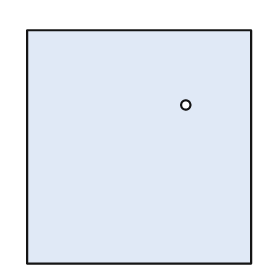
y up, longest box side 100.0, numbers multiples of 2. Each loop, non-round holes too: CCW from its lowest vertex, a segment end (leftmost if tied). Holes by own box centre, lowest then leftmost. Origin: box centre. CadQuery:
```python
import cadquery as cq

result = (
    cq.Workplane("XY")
    .moveTo(-48.0, -50.0)
    .lineTo(48.0, -50.0)
    .lineTo(48.0, 50.0)
    .lineTo(-48.0, 50.0)
    .close()
    .moveTo(20.0, 18.0)
    .circle(2.0)
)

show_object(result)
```